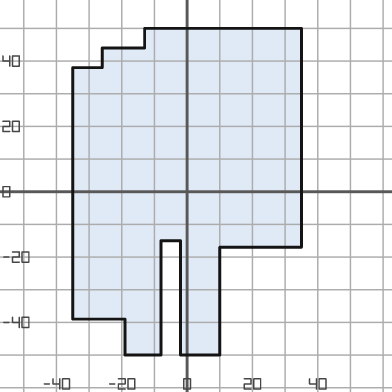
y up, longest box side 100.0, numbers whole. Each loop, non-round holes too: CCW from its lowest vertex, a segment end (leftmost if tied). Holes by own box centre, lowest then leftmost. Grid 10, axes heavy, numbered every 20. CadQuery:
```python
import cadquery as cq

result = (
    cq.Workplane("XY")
    .moveTo(-19.0, -50.0)
    .lineTo(-8.0, -50.0)
    .lineTo(-8.0, -15.0)
    .lineTo(-2.0, -15.0)
    .lineTo(-2.0, -50.0)
    .lineTo(10.0, -50.0)
    .lineTo(10.0, -17.0)
    .lineTo(35.0, -17.0)
    .lineTo(35.0, 50.0)
    .lineTo(-13.0, 50.0)
    .lineTo(-13.0, 44.0)
    .lineTo(-26.0, 44.0)
    .lineTo(-26.0, 38.0)
    .lineTo(-35.0, 38.0)
    .lineTo(-35.0, -39.0)
    .lineTo(-19.0, -39.0)
    .close()
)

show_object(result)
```